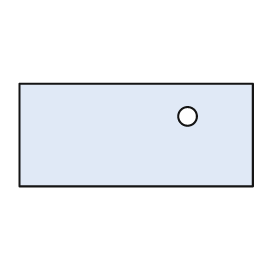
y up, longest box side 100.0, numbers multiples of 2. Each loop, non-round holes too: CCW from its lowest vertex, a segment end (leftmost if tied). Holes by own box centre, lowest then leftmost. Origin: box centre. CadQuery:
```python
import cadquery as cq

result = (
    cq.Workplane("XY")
    .moveTo(-50.0, -22.0)
    .lineTo(50.0, -22.0)
    .lineTo(50.0, 22.0)
    .lineTo(-50.0, 22.0)
    .close()
    .moveTo(22.0, 8.0)
    .circle(4.0)
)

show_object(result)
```